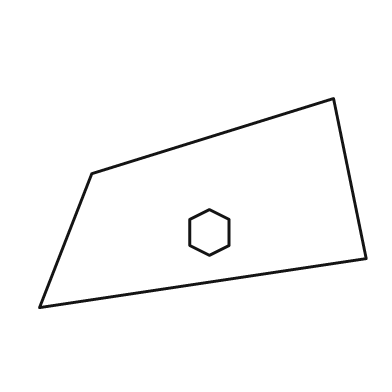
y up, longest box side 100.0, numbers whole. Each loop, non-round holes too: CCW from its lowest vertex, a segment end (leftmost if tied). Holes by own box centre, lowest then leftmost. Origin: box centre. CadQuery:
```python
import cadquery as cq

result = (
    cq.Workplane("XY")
    .moveTo(-50.0, -32.0)
    .lineTo(50.0, -17.0)
    .lineTo(40.0, 32.0)
    .lineTo(-34.0, 9.0)
    .close()
    .moveTo(2.0, -16.0)
    .lineTo(8.0, -13.0)
    .lineTo(8.0, -5.0)
    .lineTo(2.0, -2.0)
    .lineTo(-4.0, -5.0)
    .lineTo(-4.0, -13.0)
    .close()
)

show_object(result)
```